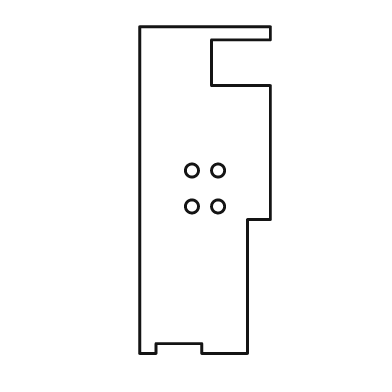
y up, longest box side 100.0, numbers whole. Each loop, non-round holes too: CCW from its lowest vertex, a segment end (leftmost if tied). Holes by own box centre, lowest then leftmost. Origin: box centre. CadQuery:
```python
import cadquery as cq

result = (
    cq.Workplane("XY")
    .moveTo(-20.0, -50.0)
    .lineTo(-15.0, -50.0)
    .lineTo(-15.0, -47.0)
    .lineTo(-1.0, -47.0)
    .lineTo(-1.0, -50.0)
    .lineTo(13.0, -50.0)
    .lineTo(13.0, -9.0)
    .lineTo(20.0, -9.0)
    .lineTo(20.0, 32.0)
    .lineTo(2.0, 32.0)
    .lineTo(2.0, 46.0)
    .lineTo(20.0, 46.0)
    .lineTo(20.0, 50.0)
    .lineTo(-20.0, 50.0)
    .close()
    .moveTo(-4.0, -5.0)
    .circle(2.0)
    .moveTo(4.0, -5.0)
    .circle(2.0)
    .moveTo(-4.0, 6.0)
    .circle(2.0)
    .moveTo(4.0, 6.0)
    .circle(2.0)
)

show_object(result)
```